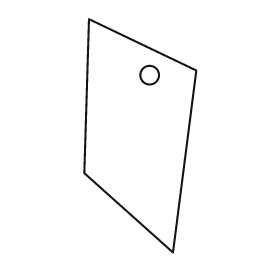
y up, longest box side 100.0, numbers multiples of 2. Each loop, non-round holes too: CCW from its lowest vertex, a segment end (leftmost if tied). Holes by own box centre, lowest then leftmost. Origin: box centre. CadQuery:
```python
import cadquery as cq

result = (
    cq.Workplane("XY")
    .moveTo(14.0, -50.0)
    .lineTo(24.0, 28.0)
    .lineTo(-22.0, 50.0)
    .lineTo(-24.0, -16.0)
    .close()
    .moveTo(4.0, 26.0)
    .circle(4.0)
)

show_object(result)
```